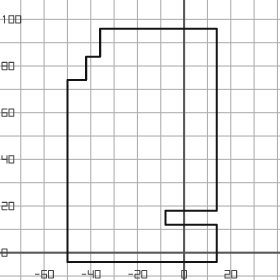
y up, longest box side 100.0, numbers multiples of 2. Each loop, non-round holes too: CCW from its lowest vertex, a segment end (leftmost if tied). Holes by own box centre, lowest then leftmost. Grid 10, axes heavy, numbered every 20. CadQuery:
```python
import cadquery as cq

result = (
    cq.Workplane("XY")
    .moveTo(-50.0, -4.0)
    .lineTo(14.0, -4.0)
    .lineTo(14.0, 12.0)
    .lineTo(-8.0, 12.0)
    .lineTo(-8.0, 18.0)
    .lineTo(14.0, 18.0)
    .lineTo(14.0, 96.0)
    .lineTo(-36.0, 96.0)
    .lineTo(-36.0, 84.0)
    .lineTo(-42.0, 84.0)
    .lineTo(-42.0, 74.0)
    .lineTo(-50.0, 74.0)
    .close()
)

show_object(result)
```